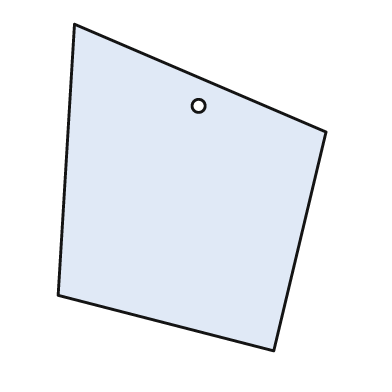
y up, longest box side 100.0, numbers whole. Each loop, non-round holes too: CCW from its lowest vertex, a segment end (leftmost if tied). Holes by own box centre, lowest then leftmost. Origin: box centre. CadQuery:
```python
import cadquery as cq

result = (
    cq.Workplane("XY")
    .moveTo(25.0, -50.0)
    .lineTo(41.0, 17.0)
    .lineTo(-36.0, 50.0)
    .lineTo(-41.0, -33.0)
    .close()
    .moveTo(2.0, 25.0)
    .circle(2.0)
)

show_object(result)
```